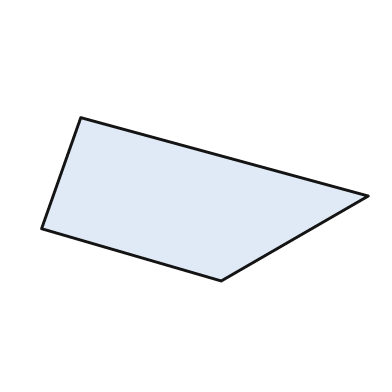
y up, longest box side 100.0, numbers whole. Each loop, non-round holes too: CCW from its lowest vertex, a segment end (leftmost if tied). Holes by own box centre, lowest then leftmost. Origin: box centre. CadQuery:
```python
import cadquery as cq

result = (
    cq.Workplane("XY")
    .moveTo(5.0, -25.0)
    .lineTo(50.0, 1.0)
    .lineTo(-38.0, 25.0)
    .lineTo(-50.0, -9.0)
    .close()
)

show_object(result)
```